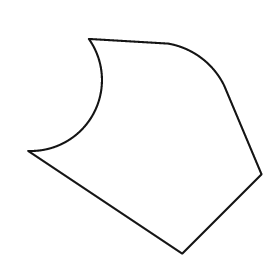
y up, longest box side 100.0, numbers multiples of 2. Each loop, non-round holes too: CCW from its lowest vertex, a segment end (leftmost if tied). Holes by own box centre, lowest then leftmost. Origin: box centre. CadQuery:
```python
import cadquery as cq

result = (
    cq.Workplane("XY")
    .moveTo(16.0, -46.0)
    .lineTo(50.0, -12.0)
    .lineTo(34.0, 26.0)
    .threePointArc((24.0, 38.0), (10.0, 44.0))
    .lineTo(-24.0, 46.0)
    .threePointArc((-22.0, 14.0), (-50.0, -2.0))
    .close()
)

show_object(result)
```